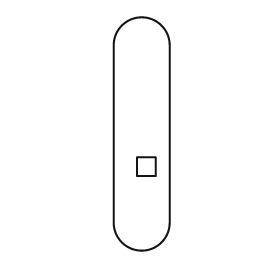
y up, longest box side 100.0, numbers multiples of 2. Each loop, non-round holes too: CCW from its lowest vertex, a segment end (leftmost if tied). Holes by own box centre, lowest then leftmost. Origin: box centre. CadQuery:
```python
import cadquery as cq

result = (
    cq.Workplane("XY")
    .moveTo(-12.0, -38.0)
    .threePointArc((0.0, -50.0), (12.0, -38.0))
    .lineTo(12.0, 38.0)
    .threePointArc((0.0, 50.0), (-12.0, 38.0))
    .close()
    .moveTo(-2.0, -18.0)
    .lineTo(6.0, -18.0)
    .lineTo(6.0, -10.0)
    .lineTo(-2.0, -10.0)
    .close()
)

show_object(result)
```